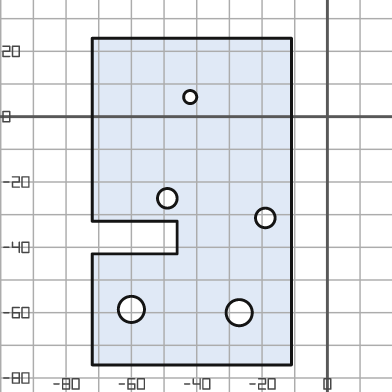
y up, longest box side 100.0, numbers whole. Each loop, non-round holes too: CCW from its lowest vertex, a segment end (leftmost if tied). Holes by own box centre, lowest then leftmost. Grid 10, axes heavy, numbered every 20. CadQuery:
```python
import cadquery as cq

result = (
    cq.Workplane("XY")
    .moveTo(-72.0, -76.0)
    .lineTo(-11.0, -76.0)
    .lineTo(-11.0, 24.0)
    .lineTo(-72.0, 24.0)
    .lineTo(-72.0, -32.0)
    .lineTo(-46.0, -32.0)
    .lineTo(-46.0, -42.0)
    .lineTo(-72.0, -42.0)
    .close()
    .moveTo(-27.0, -60.0)
    .circle(4.0)
    .moveTo(-60.0, -59.0)
    .circle(4.0)
    .moveTo(-19.0, -31.0)
    .circle(3.0)
    .moveTo(-49.0, -25.0)
    .circle(3.0)
    .moveTo(-42.0, 6.0)
    .circle(2.0)
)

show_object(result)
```